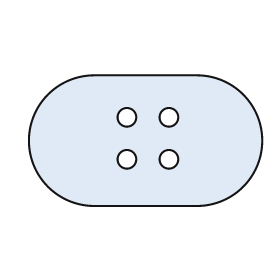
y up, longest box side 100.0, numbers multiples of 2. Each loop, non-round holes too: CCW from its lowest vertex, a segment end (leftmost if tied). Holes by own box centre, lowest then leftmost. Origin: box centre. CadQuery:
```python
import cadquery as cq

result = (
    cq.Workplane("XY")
    .moveTo(-22.0, -28.0)
    .lineTo(22.0, -28.0)
    .threePointArc((50.0, 0.0), (22.0, 28.0))
    .lineTo(-22.0, 28.0)
    .threePointArc((-50.0, 0.0), (-22.0, -28.0))
    .close()
    .moveTo(-8.0, -8.0)
    .circle(4.0)
    .moveTo(10.0, -8.0)
    .circle(4.0)
    .moveTo(-8.0, 10.0)
    .circle(4.0)
    .moveTo(10.0, 10.0)
    .circle(4.0)
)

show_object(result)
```